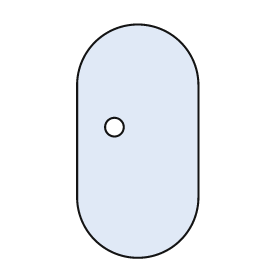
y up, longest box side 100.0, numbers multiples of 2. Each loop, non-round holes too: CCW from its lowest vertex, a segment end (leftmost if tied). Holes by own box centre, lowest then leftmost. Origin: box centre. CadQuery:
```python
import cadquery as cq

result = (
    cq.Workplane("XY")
    .moveTo(-26.0, -24.0)
    .threePointArc((0.0, -50.0), (26.0, -24.0))
    .lineTo(26.0, 24.0)
    .threePointArc((0.0, 50.0), (-26.0, 24.0))
    .close()
    .moveTo(-10.0, 6.0)
    .circle(4.0)
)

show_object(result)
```